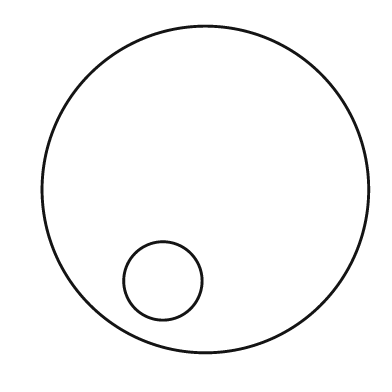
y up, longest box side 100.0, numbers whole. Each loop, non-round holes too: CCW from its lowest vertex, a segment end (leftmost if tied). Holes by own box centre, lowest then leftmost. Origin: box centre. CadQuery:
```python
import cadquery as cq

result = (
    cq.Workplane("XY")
    .moveTo(0.0, 0.0)
    .circle(50.0)
    .moveTo(-13.0, -28.0)
    .circle(12.0)
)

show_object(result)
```